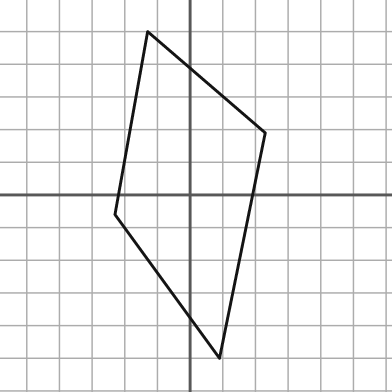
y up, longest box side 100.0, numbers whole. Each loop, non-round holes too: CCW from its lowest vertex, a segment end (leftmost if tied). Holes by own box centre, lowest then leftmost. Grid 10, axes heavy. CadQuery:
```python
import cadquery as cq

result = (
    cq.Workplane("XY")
    .moveTo(9.0, -50.0)
    .lineTo(23.0, 19.0)
    .lineTo(-13.0, 50.0)
    .lineTo(-23.0, -6.0)
    .close()
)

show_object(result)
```